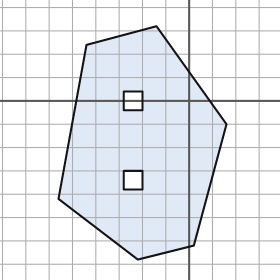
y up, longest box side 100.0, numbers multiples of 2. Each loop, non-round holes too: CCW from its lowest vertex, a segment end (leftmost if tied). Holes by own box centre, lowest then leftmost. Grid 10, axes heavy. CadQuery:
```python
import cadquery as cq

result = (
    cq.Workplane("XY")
    .moveTo(-22.0, -68.0)
    .lineTo(2.0, -62.0)
    .lineTo(16.0, -10.0)
    .lineTo(-14.0, 32.0)
    .lineTo(-44.0, 24.0)
    .lineTo(-56.0, -42.0)
    .close()
    .moveTo(-28.0, -38.0)
    .lineTo(-20.0, -38.0)
    .lineTo(-20.0, -30.0)
    .lineTo(-28.0, -30.0)
    .close()
    .moveTo(-28.0, -4.0)
    .lineTo(-20.0, -4.0)
    .lineTo(-20.0, 4.0)
    .lineTo(-28.0, 4.0)
    .close()
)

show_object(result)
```